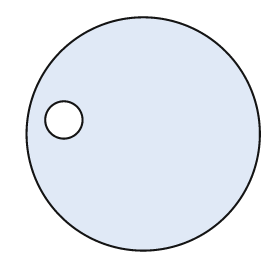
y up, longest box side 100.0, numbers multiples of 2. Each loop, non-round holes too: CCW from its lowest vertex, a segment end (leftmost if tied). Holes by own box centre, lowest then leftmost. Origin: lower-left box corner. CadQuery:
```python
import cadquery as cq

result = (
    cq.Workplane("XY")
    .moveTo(50.0, 50.0)
    .circle(50.0)
    .moveTo(16.0, 56.0)
    .circle(8.0)
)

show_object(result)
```